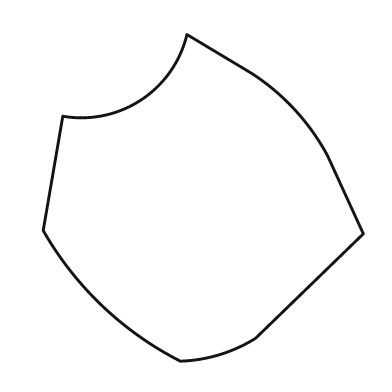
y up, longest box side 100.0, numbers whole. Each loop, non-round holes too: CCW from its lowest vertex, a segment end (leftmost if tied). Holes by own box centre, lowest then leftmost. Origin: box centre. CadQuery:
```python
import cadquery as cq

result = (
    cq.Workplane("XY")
    .moveTo(-7.0, -50.0)
    .threePointArc((5.0, -48.0), (16.0, -43.0))
    .lineTo(49.0, -11.0)
    .lineTo(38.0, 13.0)
    .threePointArc((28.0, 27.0), (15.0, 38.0))
    .lineTo(-5.0, 50.0)
    .threePointArc((-19.0, 30.0), (-43.0, 25.0))
    .lineTo(-49.0, -10.0)
    .threePointArc((-31.0, -33.0), (-7.0, -50.0))
    .close()
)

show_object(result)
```